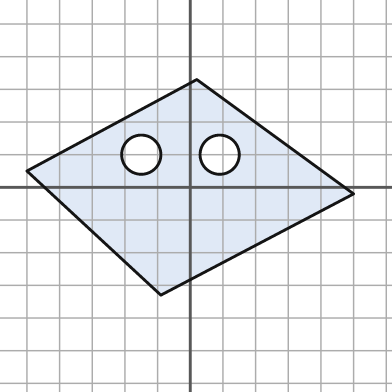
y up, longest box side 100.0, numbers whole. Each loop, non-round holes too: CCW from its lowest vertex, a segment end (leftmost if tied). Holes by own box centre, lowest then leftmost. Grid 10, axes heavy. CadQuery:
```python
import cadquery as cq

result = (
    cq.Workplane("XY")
    .moveTo(-9.0, -33.0)
    .lineTo(50.0, -2.0)
    .lineTo(2.0, 33.0)
    .lineTo(-50.0, 5.0)
    .close()
    .moveTo(-15.0, 10.0)
    .circle(6.0)
    .moveTo(9.0, 10.0)
    .circle(6.0)
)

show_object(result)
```